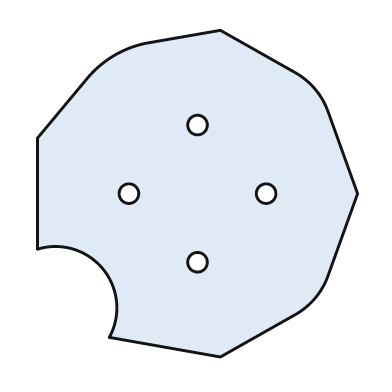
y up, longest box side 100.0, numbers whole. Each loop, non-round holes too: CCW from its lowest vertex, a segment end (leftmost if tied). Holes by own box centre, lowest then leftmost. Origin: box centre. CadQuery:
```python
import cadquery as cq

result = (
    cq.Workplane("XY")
    .moveTo(7.0, -50.0)
    .lineTo(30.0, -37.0)
    .threePointArc((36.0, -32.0), (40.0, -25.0))
    .lineTo(49.0, 0.0)
    .lineTo(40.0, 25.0)
    .threePointArc((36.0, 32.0), (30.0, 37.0))
    .lineTo(7.0, 50.0)
    .lineTo(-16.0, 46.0)
    .threePointArc((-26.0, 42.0), (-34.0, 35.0))
    .lineTo(-49.0, 17.0)
    .lineTo(-49.0, -17.0)
    .threePointArc((-29.0, -23.0), (-27.0, -44.0))
    .close()
    .moveTo(0.0, -21.0)
    .circle(3.0)
    .moveTo(-21.0, 0.0)
    .circle(3.0)
    .moveTo(21.0, 0.0)
    .circle(3.0)
    .moveTo(0.0, 21.0)
    .circle(3.0)
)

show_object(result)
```